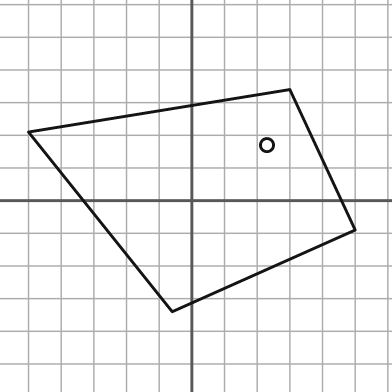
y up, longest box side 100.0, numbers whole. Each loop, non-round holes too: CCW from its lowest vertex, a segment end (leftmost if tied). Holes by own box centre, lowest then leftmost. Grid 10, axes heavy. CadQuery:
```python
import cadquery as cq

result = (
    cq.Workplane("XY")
    .moveTo(-6.0, -34.0)
    .lineTo(50.0, -9.0)
    .lineTo(30.0, 34.0)
    .lineTo(-50.0, 21.0)
    .close()
    .moveTo(23.0, 17.0)
    .circle(2.0)
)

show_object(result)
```